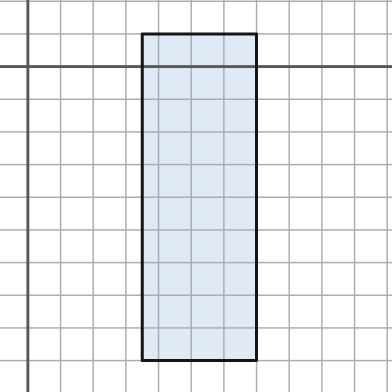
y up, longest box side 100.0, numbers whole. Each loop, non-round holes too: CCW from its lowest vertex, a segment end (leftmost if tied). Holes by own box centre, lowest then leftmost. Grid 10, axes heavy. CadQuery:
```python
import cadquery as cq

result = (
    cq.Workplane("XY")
    .moveTo(35.0, -90.0)
    .lineTo(70.0, -90.0)
    .lineTo(70.0, 10.0)
    .lineTo(35.0, 10.0)
    .close()
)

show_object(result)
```